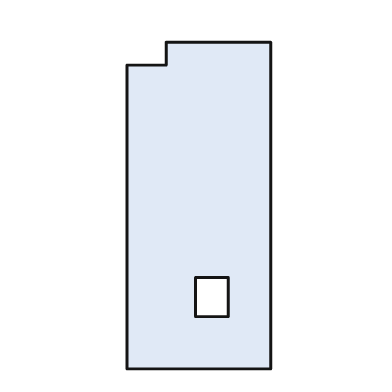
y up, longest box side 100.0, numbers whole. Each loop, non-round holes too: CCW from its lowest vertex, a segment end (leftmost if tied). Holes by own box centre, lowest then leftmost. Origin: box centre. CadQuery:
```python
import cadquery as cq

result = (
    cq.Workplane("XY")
    .moveTo(-22.0, -50.0)
    .lineTo(22.0, -50.0)
    .lineTo(22.0, 50.0)
    .lineTo(-10.0, 50.0)
    .lineTo(-10.0, 43.0)
    .lineTo(-22.0, 43.0)
    .close()
    .moveTo(-1.0, -34.0)
    .lineTo(9.0, -34.0)
    .lineTo(9.0, -22.0)
    .lineTo(-1.0, -22.0)
    .close()
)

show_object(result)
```